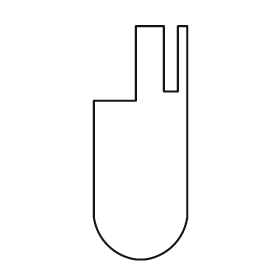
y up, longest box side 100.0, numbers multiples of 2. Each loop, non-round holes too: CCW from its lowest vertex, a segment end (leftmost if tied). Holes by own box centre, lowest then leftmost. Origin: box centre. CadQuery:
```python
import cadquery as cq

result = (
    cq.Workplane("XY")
    .moveTo(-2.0, -50.0)
    .lineTo(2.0, -50.0)
    .threePointArc((14.0, -44.0), (20.0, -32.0))
    .lineTo(20.0, 50.0)
    .lineTo(16.0, 50.0)
    .lineTo(16.0, 22.0)
    .lineTo(10.0, 22.0)
    .lineTo(10.0, 50.0)
    .lineTo(-2.0, 50.0)
    .lineTo(-2.0, 18.0)
    .lineTo(-20.0, 18.0)
    .lineTo(-20.0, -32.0)
    .threePointArc((-14.0, -44.0), (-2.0, -50.0))
    .close()
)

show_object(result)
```